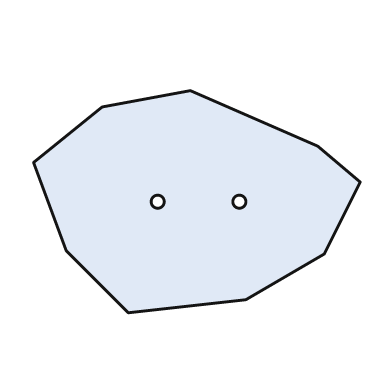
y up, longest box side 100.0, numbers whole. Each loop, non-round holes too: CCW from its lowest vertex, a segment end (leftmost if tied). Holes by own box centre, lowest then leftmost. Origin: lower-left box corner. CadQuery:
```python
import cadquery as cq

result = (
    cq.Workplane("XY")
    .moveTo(29.0, 0.0)
    .lineTo(65.0, 4.0)
    .lineTo(89.0, 18.0)
    .lineTo(100.0, 40.0)
    .lineTo(87.0, 51.0)
    .lineTo(48.0, 68.0)
    .lineTo(21.0, 63.0)
    .lineTo(0.0, 46.0)
    .lineTo(10.0, 19.0)
    .close()
    .moveTo(38.0, 34.0)
    .circle(2.0)
    .moveTo(63.0, 34.0)
    .circle(2.0)
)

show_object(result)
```